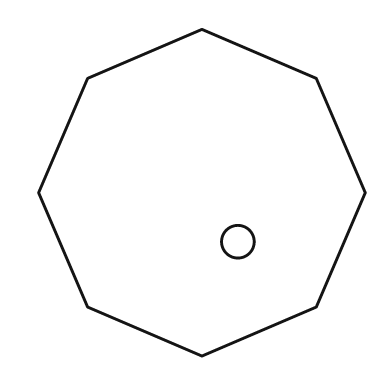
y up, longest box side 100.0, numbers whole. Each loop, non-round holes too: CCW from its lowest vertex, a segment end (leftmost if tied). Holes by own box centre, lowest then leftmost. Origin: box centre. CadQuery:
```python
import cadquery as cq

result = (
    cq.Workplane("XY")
    .moveTo(0.0, -50.0)
    .lineTo(35.0, -35.0)
    .lineTo(50.0, 0.0)
    .lineTo(35.0, 35.0)
    .lineTo(0.0, 50.0)
    .lineTo(-35.0, 35.0)
    .lineTo(-50.0, 0.0)
    .lineTo(-35.0, -35.0)
    .close()
    .moveTo(11.0, -15.0)
    .circle(5.0)
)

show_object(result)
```